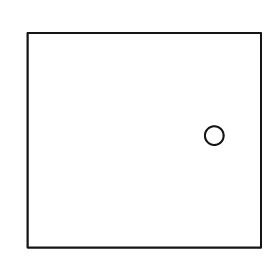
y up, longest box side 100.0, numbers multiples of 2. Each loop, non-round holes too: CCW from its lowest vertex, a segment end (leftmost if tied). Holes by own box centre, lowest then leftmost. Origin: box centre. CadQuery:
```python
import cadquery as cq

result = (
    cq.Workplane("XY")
    .moveTo(-50.0, -46.0)
    .lineTo(50.0, -46.0)
    .lineTo(50.0, 46.0)
    .lineTo(-50.0, 46.0)
    .close()
    .moveTo(30.0, 2.0)
    .circle(4.0)
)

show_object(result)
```